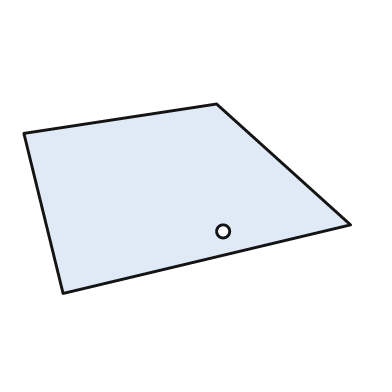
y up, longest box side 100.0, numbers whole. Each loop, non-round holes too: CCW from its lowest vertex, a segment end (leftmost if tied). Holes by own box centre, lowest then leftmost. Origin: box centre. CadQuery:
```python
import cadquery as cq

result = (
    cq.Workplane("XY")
    .moveTo(-38.0, -29.0)
    .lineTo(50.0, -8.0)
    .lineTo(9.0, 29.0)
    .lineTo(-50.0, 20.0)
    .close()
    .moveTo(11.0, -10.0)
    .circle(2.0)
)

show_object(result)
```